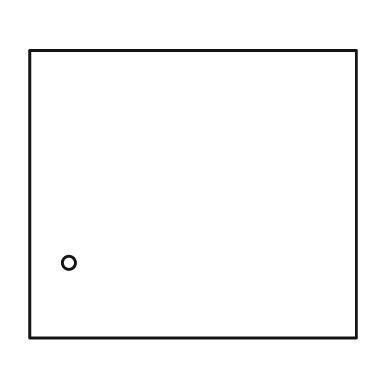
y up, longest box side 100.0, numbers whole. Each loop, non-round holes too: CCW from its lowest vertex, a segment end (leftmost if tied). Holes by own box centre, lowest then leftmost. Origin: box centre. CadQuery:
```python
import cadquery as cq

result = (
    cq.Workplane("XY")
    .moveTo(-50.0, -44.0)
    .lineTo(50.0, -44.0)
    .lineTo(50.0, 44.0)
    .lineTo(-50.0, 44.0)
    .close()
    .moveTo(-38.0, -21.0)
    .circle(2.0)
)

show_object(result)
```